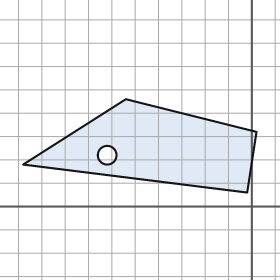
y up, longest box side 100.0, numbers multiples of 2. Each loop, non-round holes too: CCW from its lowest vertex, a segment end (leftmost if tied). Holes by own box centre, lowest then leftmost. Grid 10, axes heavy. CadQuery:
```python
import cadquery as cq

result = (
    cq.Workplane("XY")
    .moveTo(-2.0, 6.0)
    .lineTo(2.0, 32.0)
    .lineTo(-54.0, 46.0)
    .lineTo(-98.0, 18.0)
    .close()
    .moveTo(-62.0, 22.0)
    .circle(4.0)
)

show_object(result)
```